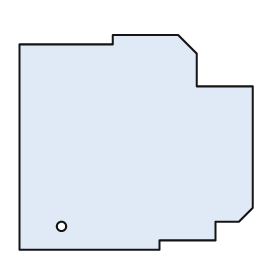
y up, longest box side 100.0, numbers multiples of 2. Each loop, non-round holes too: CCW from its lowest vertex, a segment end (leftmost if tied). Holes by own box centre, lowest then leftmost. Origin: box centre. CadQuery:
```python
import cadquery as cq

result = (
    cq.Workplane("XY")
    .moveTo(-50.0, -46.0)
    .lineTo(10.0, -46.0)
    .lineTo(10.0, -42.0)
    .lineTo(34.0, -42.0)
    .lineTo(34.0, -34.0)
    .lineTo(44.0, -34.0)
    .lineTo(50.0, -28.0)
    .lineTo(50.0, 24.0)
    .lineTo(26.0, 24.0)
    .lineTo(26.0, 38.0)
    .lineTo(18.0, 46.0)
    .lineTo(-10.0, 46.0)
    .lineTo(-10.0, 42.0)
    .lineTo(-50.0, 42.0)
    .close()
    .moveTo(-32.0, -36.0)
    .circle(2.0)
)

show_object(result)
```